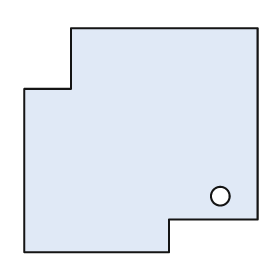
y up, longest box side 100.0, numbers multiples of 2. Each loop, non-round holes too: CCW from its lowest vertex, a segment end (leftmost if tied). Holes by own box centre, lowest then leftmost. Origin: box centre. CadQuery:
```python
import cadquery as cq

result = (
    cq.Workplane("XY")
    .moveTo(-50.0, -48.0)
    .lineTo(12.0, -48.0)
    .lineTo(12.0, -34.0)
    .lineTo(50.0, -34.0)
    .lineTo(50.0, 48.0)
    .lineTo(-30.0, 48.0)
    .lineTo(-30.0, 22.0)
    .lineTo(-50.0, 22.0)
    .close()
    .moveTo(34.0, -24.0)
    .circle(4.0)
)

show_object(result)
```